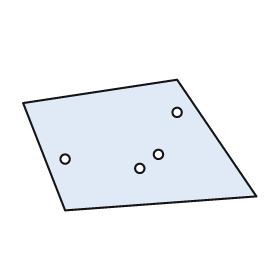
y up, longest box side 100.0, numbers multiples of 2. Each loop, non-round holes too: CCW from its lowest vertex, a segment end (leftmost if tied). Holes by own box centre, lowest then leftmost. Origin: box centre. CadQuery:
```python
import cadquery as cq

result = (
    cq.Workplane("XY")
    .moveTo(-32.0, -28.0)
    .lineTo(50.0, -22.0)
    .lineTo(16.0, 28.0)
    .lineTo(-50.0, 18.0)
    .close()
    .moveTo(0.0, -10.0)
    .circle(2.0)
    .moveTo(-32.0, -6.0)
    .circle(2.0)
    .moveTo(8.0, -4.0)
    .circle(2.0)
    .moveTo(16.0, 14.0)
    .circle(2.0)
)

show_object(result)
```